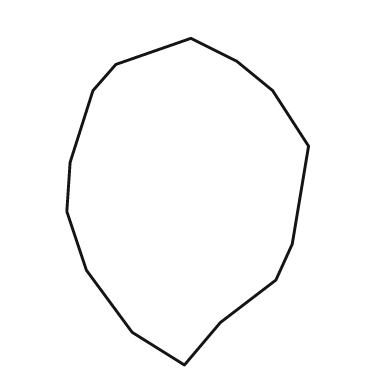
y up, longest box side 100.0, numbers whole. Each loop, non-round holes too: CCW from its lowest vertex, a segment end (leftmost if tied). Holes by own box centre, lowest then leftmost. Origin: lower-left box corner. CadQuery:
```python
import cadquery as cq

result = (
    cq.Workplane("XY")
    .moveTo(36.0, 0.0)
    .lineTo(47.0, 13.0)
    .lineTo(64.0, 26.0)
    .lineTo(69.0, 37.0)
    .lineTo(74.0, 67.0)
    .lineTo(63.0, 84.0)
    .lineTo(52.0, 93.0)
    .lineTo(38.0, 100.0)
    .lineTo(15.0, 92.0)
    .lineTo(8.0, 84.0)
    .lineTo(1.0, 62.0)
    .lineTo(0.0, 47.0)
    .lineTo(6.0, 29.0)
    .lineTo(20.0, 10.0)
    .close()
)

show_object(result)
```